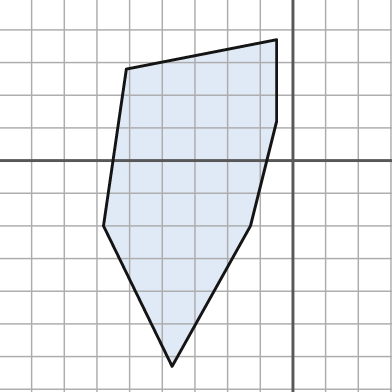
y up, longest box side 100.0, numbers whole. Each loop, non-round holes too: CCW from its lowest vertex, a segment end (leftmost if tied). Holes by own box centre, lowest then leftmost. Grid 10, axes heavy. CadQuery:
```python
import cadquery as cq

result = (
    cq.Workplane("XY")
    .moveTo(-37.0, -63.0)
    .lineTo(-13.0, -20.0)
    .lineTo(-5.0, 12.0)
    .lineTo(-5.0, 37.0)
    .lineTo(-51.0, 28.0)
    .lineTo(-58.0, -20.0)
    .close()
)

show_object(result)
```